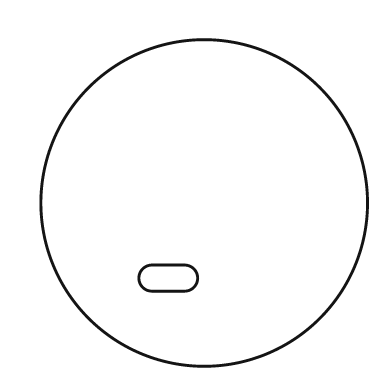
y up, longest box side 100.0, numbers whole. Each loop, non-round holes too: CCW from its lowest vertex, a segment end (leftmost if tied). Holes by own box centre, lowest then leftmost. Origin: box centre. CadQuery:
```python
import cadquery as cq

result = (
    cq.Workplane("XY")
    .moveTo(0.0, 0.0)
    .circle(50.0)
    .moveTo(-16.0, -27.0)
    .lineTo(-6.0, -27.0)
    .threePointArc((-2.0, -23.0), (-6.0, -19.0))
    .lineTo(-16.0, -19.0)
    .threePointArc((-20.0, -23.0), (-16.0, -27.0))
    .close()
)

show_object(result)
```